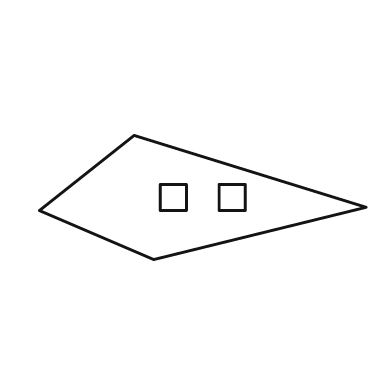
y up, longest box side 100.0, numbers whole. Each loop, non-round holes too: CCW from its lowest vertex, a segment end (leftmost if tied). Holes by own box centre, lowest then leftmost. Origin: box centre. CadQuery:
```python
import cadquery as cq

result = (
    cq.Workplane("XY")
    .moveTo(-15.0, -19.0)
    .lineTo(50.0, -3.0)
    .lineTo(-21.0, 19.0)
    .lineTo(-50.0, -4.0)
    .close()
    .moveTo(-13.0, -4.0)
    .lineTo(-5.0, -4.0)
    .lineTo(-5.0, 4.0)
    .lineTo(-13.0, 4.0)
    .close()
    .moveTo(5.0, -4.0)
    .lineTo(13.0, -4.0)
    .lineTo(13.0, 4.0)
    .lineTo(5.0, 4.0)
    .close()
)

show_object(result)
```